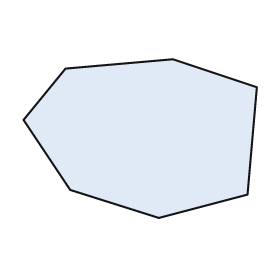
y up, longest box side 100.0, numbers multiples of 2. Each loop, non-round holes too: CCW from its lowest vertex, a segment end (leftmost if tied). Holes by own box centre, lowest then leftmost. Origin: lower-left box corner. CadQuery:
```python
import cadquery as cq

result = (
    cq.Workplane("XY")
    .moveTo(58.0, 0.0)
    .lineTo(96.0, 10.0)
    .lineTo(100.0, 56.0)
    .lineTo(64.0, 68.0)
    .lineTo(18.0, 64.0)
    .lineTo(0.0, 42.0)
    .lineTo(20.0, 12.0)
    .close()
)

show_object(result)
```